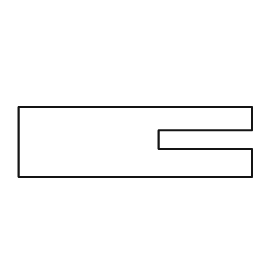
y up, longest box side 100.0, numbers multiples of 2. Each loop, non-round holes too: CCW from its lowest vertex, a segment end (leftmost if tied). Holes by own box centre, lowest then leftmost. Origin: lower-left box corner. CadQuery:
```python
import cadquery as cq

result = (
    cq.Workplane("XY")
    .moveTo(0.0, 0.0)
    .lineTo(100.0, 0.0)
    .lineTo(100.0, 12.0)
    .lineTo(60.0, 12.0)
    .lineTo(60.0, 20.0)
    .lineTo(100.0, 20.0)
    .lineTo(100.0, 30.0)
    .lineTo(0.0, 30.0)
    .close()
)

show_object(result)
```